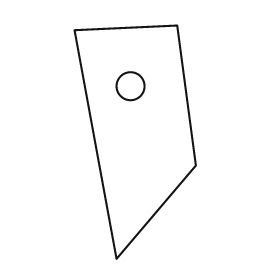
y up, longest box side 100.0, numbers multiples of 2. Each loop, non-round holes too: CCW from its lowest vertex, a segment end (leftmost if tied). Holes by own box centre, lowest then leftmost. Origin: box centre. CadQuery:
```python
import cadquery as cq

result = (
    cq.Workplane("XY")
    .moveTo(-8.0, -50.0)
    .lineTo(26.0, -10.0)
    .lineTo(18.0, 50.0)
    .lineTo(-26.0, 48.0)
    .close()
    .moveTo(-2.0, 24.0)
    .circle(6.0)
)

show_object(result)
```